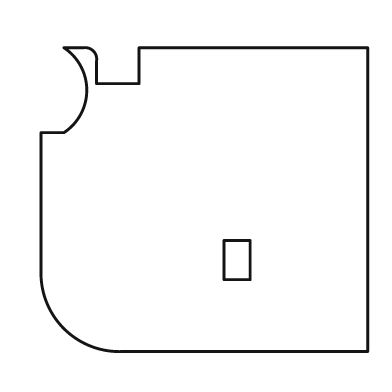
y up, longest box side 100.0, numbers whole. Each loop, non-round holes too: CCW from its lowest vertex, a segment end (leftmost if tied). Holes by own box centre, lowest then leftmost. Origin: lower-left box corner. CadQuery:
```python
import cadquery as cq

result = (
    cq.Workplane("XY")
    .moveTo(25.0, 0.0)
    .lineTo(100.0, 0.0)
    .lineTo(100.0, 93.0)
    .lineTo(30.0, 93.0)
    .lineTo(30.0, 82.0)
    .lineTo(17.0, 82.0)
    .lineTo(17.0, 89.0)
    .threePointArc((16.0, 92.0), (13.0, 93.0))
    .lineTo(7.0, 93.0)
    .threePointArc((14.0, 80.0), (7.0, 67.0))
    .lineTo(0.0, 67.0)
    .lineTo(0.0, 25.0)
    .threePointArc((7.0, 7.0), (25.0, 0.0))
    .close()
    .moveTo(56.0, 22.0)
    .lineTo(64.0, 22.0)
    .lineTo(64.0, 34.0)
    .lineTo(56.0, 34.0)
    .close()
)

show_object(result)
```